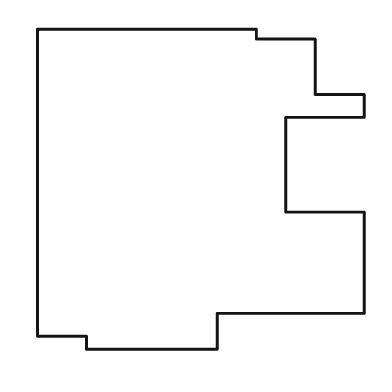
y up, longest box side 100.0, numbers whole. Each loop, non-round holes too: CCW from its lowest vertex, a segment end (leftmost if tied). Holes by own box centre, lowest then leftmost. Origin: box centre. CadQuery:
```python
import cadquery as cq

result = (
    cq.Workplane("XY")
    .moveTo(-35.0, -49.0)
    .lineTo(5.0, -49.0)
    .lineTo(5.0, -38.0)
    .lineTo(50.0, -38.0)
    .lineTo(50.0, -7.0)
    .lineTo(26.0, -7.0)
    .lineTo(26.0, 22.0)
    .lineTo(50.0, 22.0)
    .lineTo(50.0, 29.0)
    .lineTo(35.0, 29.0)
    .lineTo(35.0, 46.0)
    .lineTo(17.0, 46.0)
    .lineTo(17.0, 49.0)
    .lineTo(-50.0, 49.0)
    .lineTo(-50.0, -45.0)
    .lineTo(-35.0, -45.0)
    .close()
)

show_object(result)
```